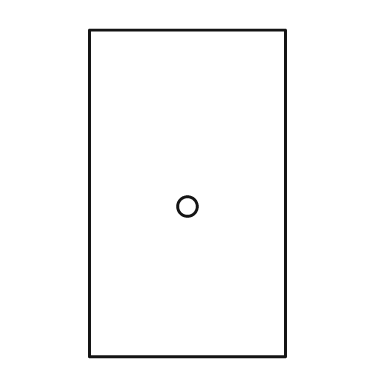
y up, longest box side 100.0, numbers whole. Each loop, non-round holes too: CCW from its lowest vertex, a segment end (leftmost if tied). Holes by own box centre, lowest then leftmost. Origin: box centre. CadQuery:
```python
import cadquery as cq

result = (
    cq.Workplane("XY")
    .moveTo(-30.0, -50.0)
    .lineTo(30.0, -50.0)
    .lineTo(30.0, 50.0)
    .lineTo(-30.0, 50.0)
    .close()
    .moveTo(0.0, -4.0)
    .circle(3.0)
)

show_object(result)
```